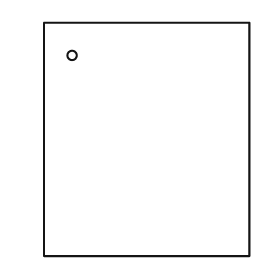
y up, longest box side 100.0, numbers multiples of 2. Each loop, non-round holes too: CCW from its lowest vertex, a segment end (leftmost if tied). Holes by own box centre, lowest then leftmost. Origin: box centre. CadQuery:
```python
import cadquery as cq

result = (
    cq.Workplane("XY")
    .moveTo(-44.0, -50.0)
    .lineTo(44.0, -50.0)
    .lineTo(44.0, 50.0)
    .lineTo(-44.0, 50.0)
    .close()
    .moveTo(-32.0, 36.0)
    .circle(2.0)
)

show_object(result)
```